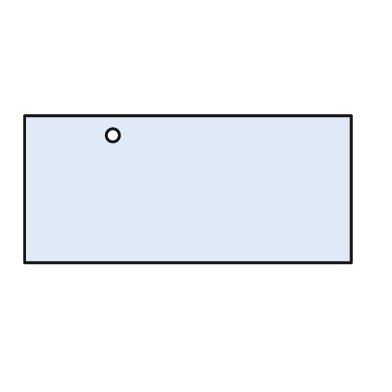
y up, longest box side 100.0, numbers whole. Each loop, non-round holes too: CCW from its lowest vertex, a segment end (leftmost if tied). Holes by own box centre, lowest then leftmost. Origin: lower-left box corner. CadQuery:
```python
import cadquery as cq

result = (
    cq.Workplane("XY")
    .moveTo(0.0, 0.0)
    .lineTo(100.0, 0.0)
    .lineTo(100.0, 45.0)
    .lineTo(0.0, 45.0)
    .close()
    .moveTo(27.0, 39.0)
    .circle(2.0)
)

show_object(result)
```